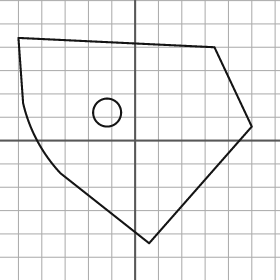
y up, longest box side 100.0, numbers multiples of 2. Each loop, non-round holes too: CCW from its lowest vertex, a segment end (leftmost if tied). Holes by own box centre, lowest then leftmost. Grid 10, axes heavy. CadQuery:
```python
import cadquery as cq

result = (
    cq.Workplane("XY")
    .moveTo(6.0, -44.0)
    .lineTo(50.0, 6.0)
    .lineTo(34.0, 40.0)
    .lineTo(-50.0, 44.0)
    .lineTo(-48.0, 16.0)
    .threePointArc((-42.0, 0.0), (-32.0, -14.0))
    .close()
    .moveTo(-12.0, 12.0)
    .circle(6.0)
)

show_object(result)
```